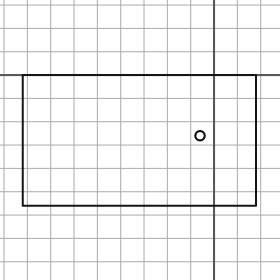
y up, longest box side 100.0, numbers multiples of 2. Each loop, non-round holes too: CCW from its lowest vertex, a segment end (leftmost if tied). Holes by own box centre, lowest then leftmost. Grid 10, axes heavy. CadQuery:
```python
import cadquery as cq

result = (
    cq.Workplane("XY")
    .moveTo(-82.0, -56.0)
    .lineTo(18.0, -56.0)
    .lineTo(18.0, 0.0)
    .lineTo(-82.0, 0.0)
    .close()
    .moveTo(-6.0, -26.0)
    .circle(2.0)
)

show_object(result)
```